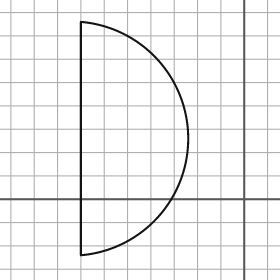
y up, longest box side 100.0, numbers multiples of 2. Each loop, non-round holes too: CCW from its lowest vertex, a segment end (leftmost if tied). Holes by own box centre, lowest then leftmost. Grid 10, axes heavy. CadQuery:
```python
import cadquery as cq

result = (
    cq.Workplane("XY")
    .moveTo(-70.0, -24.0)
    .threePointArc((-24.0, 26.0), (-70.0, 76.0))
    .close()
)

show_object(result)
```